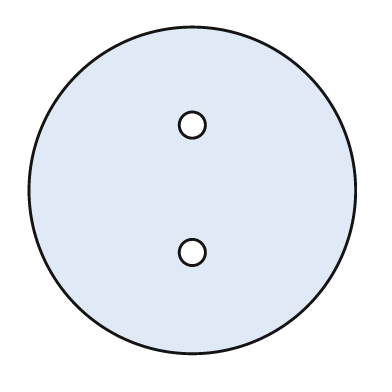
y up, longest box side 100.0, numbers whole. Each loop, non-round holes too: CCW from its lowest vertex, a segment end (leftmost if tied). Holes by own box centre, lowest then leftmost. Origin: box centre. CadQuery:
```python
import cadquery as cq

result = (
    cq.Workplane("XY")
    .moveTo(0.0, 0.0)
    .circle(50.0)
    .moveTo(0.0, -19.0)
    .circle(4.0)
    .moveTo(0.0, 20.0)
    .circle(4.0)
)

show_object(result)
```